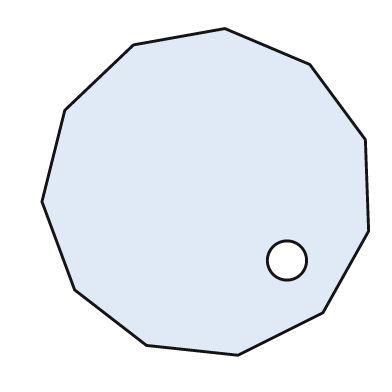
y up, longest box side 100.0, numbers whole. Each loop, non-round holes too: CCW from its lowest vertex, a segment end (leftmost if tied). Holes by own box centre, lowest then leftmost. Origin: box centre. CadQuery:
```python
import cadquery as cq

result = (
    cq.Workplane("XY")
    .moveTo(10.0, -50.0)
    .lineTo(36.0, -37.0)
    .lineTo(50.0, -12.0)
    .lineTo(49.0, 16.0)
    .lineTo(32.0, 39.0)
    .lineTo(6.0, 50.0)
    .lineTo(-22.0, 45.0)
    .lineTo(-43.0, 25.0)
    .lineTo(-50.0, -3.0)
    .lineTo(-40.0, -30.0)
    .lineTo(-18.0, -47.0)
    .close()
    .moveTo(25.0, -21.0)
    .circle(6.0)
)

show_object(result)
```